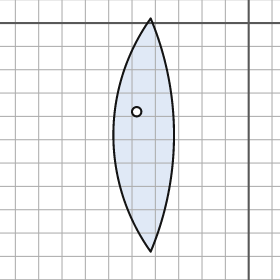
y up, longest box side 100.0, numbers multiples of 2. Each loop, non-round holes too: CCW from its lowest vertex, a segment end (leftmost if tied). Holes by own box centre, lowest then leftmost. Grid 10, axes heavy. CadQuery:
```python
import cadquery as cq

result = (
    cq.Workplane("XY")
    .moveTo(-42.0, -98.0)
    .threePointArc((-32.0, -48.0), (-42.0, 2.0))
    .threePointArc((-58.0, -48.0), (-42.0, -98.0))
    .close()
    .moveTo(-48.0, -38.0)
    .circle(2.0)
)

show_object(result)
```